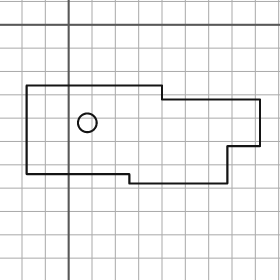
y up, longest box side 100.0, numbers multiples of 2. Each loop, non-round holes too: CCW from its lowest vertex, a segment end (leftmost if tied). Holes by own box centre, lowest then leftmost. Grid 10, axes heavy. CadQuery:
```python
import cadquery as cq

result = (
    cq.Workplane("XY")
    .moveTo(26.0, -68.0)
    .lineTo(68.0, -68.0)
    .lineTo(68.0, -52.0)
    .lineTo(82.0, -52.0)
    .lineTo(82.0, -32.0)
    .lineTo(40.0, -32.0)
    .lineTo(40.0, -26.0)
    .lineTo(-18.0, -26.0)
    .lineTo(-18.0, -64.0)
    .lineTo(26.0, -64.0)
    .close()
    .moveTo(8.0, -42.0)
    .circle(4.0)
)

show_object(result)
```